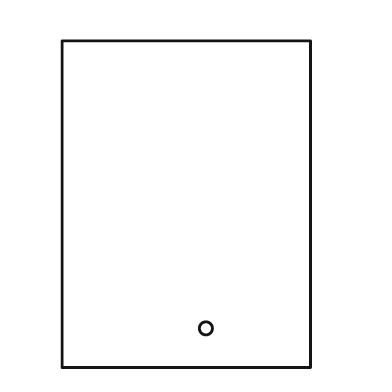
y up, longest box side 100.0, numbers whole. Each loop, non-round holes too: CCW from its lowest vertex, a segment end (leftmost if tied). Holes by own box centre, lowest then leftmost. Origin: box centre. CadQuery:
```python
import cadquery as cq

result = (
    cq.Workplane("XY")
    .moveTo(-38.0, -50.0)
    .lineTo(38.0, -50.0)
    .lineTo(38.0, 50.0)
    .lineTo(-38.0, 50.0)
    .close()
    .moveTo(6.0, -38.0)
    .circle(2.0)
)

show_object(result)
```